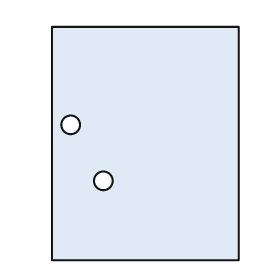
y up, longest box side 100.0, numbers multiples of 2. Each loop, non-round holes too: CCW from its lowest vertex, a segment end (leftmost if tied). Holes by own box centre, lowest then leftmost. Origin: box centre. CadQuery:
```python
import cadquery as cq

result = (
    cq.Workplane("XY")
    .moveTo(-40.0, -50.0)
    .lineTo(40.0, -50.0)
    .lineTo(40.0, 50.0)
    .lineTo(-40.0, 50.0)
    .close()
    .moveTo(-18.0, -16.0)
    .circle(4.0)
    .moveTo(-32.0, 8.0)
    .circle(4.0)
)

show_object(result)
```